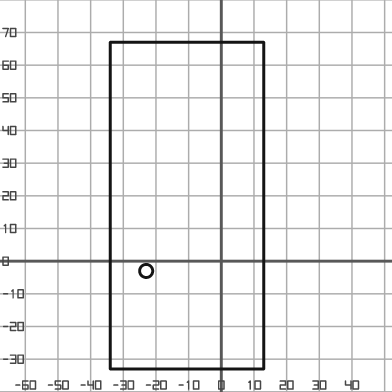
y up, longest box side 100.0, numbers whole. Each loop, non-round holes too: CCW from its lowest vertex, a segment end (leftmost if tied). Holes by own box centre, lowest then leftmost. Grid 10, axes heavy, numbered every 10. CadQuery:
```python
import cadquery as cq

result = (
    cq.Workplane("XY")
    .moveTo(-34.0, -33.0)
    .lineTo(13.0, -33.0)
    .lineTo(13.0, 67.0)
    .lineTo(-34.0, 67.0)
    .close()
    .moveTo(-23.0, -3.0)
    .circle(2.0)
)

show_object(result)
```